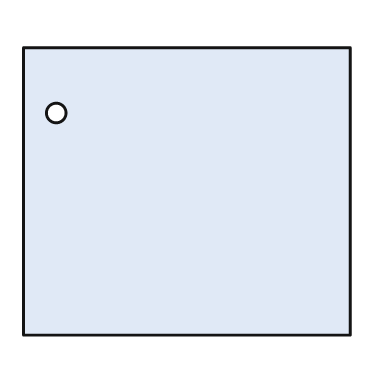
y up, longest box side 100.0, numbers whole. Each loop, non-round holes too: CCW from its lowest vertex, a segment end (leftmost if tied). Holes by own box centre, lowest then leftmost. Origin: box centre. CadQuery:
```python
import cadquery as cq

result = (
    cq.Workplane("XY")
    .moveTo(-50.0, -44.0)
    .lineTo(50.0, -44.0)
    .lineTo(50.0, 44.0)
    .lineTo(-50.0, 44.0)
    .close()
    .moveTo(-40.0, 24.0)
    .circle(3.0)
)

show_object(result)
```